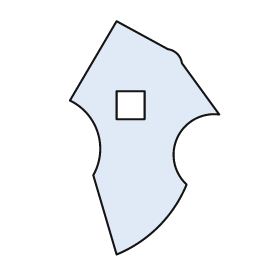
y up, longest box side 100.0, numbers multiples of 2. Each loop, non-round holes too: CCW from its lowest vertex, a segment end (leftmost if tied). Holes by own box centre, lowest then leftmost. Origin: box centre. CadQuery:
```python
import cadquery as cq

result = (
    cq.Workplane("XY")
    .moveTo(-12.0, -50.0)
    .threePointArc((6.0, -38.0), (18.0, -20.0))
    .threePointArc((14.0, 0.0), (32.0, 10.0))
    .lineTo(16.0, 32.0)
    .threePointArc((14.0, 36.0), (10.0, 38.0))
    .lineTo(-12.0, 50.0)
    .lineTo(-32.0, 16.0)
    .threePointArc((-20.0, 2.0), (-22.0, -16.0))
    .close()
    .moveTo(-12.0, 8.0)
    .lineTo(0.0, 8.0)
    .lineTo(0.0, 20.0)
    .lineTo(-12.0, 20.0)
    .close()
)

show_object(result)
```